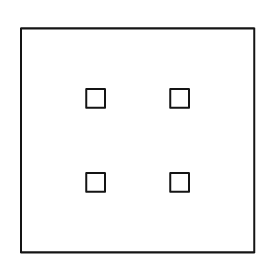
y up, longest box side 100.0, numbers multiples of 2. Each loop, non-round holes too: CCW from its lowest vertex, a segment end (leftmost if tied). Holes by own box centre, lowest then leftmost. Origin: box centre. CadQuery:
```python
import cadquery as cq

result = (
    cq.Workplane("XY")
    .moveTo(-50.0, -48.0)
    .lineTo(50.0, -48.0)
    .lineTo(50.0, 48.0)
    .lineTo(-50.0, 48.0)
    .close()
    .moveTo(-22.0, -22.0)
    .lineTo(-14.0, -22.0)
    .lineTo(-14.0, -14.0)
    .lineTo(-22.0, -14.0)
    .close()
    .moveTo(14.0, -22.0)
    .lineTo(22.0, -22.0)
    .lineTo(22.0, -14.0)
    .lineTo(14.0, -14.0)
    .close()
    .moveTo(-22.0, 14.0)
    .lineTo(-14.0, 14.0)
    .lineTo(-14.0, 22.0)
    .lineTo(-22.0, 22.0)
    .close()
    .moveTo(14.0, 14.0)
    .lineTo(22.0, 14.0)
    .lineTo(22.0, 22.0)
    .lineTo(14.0, 22.0)
    .close()
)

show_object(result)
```